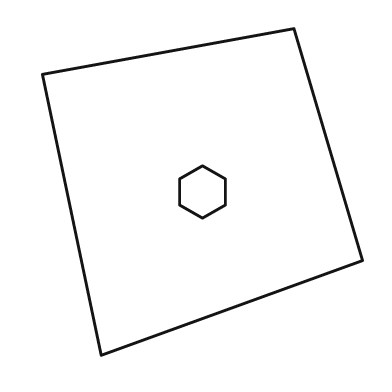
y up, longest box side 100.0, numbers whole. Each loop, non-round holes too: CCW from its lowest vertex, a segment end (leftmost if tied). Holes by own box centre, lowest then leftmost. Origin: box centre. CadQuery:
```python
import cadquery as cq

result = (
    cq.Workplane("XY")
    .moveTo(-31.0, -50.0)
    .lineTo(49.0, -21.0)
    .lineTo(28.0, 50.0)
    .lineTo(-49.0, 36.0)
    .close()
    .moveTo(0.0, -8.0)
    .lineTo(7.0, -4.0)
    .lineTo(7.0, 4.0)
    .lineTo(0.0, 8.0)
    .lineTo(-7.0, 4.0)
    .lineTo(-7.0, -4.0)
    .close()
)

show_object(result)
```